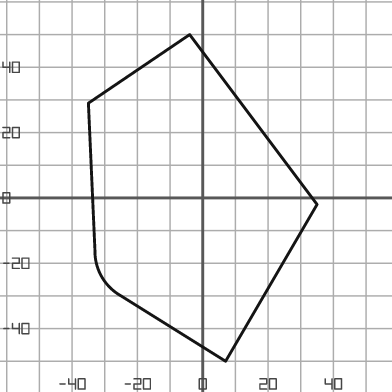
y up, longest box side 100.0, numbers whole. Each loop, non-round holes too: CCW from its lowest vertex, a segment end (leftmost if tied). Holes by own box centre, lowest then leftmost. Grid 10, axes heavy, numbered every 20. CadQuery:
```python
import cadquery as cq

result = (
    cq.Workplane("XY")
    .moveTo(7.0, -50.0)
    .lineTo(35.0, -2.0)
    .lineTo(-4.0, 50.0)
    .lineTo(-35.0, 29.0)
    .lineTo(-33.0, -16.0)
    .threePointArc((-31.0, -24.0), (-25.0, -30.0))
    .close()
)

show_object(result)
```